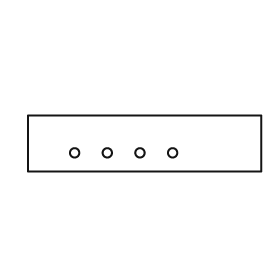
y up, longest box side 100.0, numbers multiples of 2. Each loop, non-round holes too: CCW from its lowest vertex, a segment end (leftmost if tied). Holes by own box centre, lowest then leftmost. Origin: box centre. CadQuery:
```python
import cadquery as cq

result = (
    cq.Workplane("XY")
    .moveTo(-50.0, -12.0)
    .lineTo(50.0, -12.0)
    .lineTo(50.0, 12.0)
    .lineTo(-50.0, 12.0)
    .close()
    .moveTo(-30.0, -4.0)
    .circle(2.0)
    .moveTo(-16.0, -4.0)
    .circle(2.0)
    .moveTo(-2.0, -4.0)
    .circle(2.0)
    .moveTo(12.0, -4.0)
    .circle(2.0)
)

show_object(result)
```